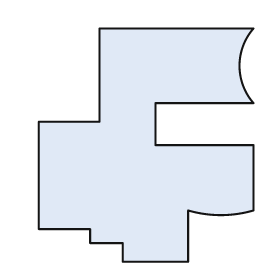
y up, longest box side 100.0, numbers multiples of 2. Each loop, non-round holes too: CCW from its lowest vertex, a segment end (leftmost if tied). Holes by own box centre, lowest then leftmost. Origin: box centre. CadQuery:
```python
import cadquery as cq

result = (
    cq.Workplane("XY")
    .moveTo(-10.0, -50.0)
    .lineTo(18.0, -50.0)
    .lineTo(18.0, -28.0)
    .threePointArc((32.0, -30.0), (46.0, -28.0))
    .lineTo(46.0, 0.0)
    .lineTo(4.0, 0.0)
    .lineTo(4.0, 18.0)
    .lineTo(46.0, 18.0)
    .threePointArc((40.0, 34.0), (46.0, 50.0))
    .lineTo(-20.0, 50.0)
    .lineTo(-20.0, 10.0)
    .lineTo(-46.0, 10.0)
    .lineTo(-46.0, -36.0)
    .lineTo(-24.0, -36.0)
    .lineTo(-24.0, -42.0)
    .lineTo(-10.0, -42.0)
    .close()
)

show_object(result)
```